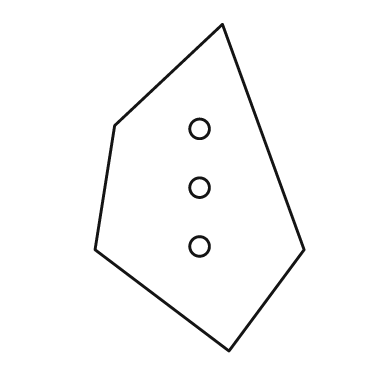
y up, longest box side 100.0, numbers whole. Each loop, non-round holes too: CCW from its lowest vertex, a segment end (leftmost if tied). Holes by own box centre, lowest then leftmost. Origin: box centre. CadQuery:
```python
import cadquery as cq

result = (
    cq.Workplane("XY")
    .moveTo(9.0, -50.0)
    .lineTo(32.0, -19.0)
    .lineTo(7.0, 50.0)
    .lineTo(-26.0, 19.0)
    .lineTo(-32.0, -19.0)
    .close()
    .moveTo(0.0, -18.0)
    .circle(3.0)
    .moveTo(0.0, 0.0)
    .circle(3.0)
    .moveTo(0.0, 18.0)
    .circle(3.0)
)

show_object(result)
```